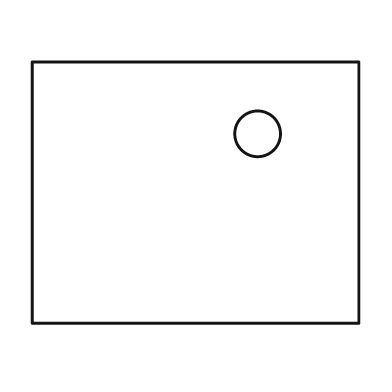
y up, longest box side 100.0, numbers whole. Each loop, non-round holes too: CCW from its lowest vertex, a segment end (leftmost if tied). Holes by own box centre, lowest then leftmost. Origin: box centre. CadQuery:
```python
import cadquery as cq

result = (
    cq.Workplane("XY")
    .moveTo(-50.0, -40.0)
    .lineTo(50.0, -40.0)
    .lineTo(50.0, 40.0)
    .lineTo(-50.0, 40.0)
    .close()
    .moveTo(19.0, 18.0)
    .circle(7.0)
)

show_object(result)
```